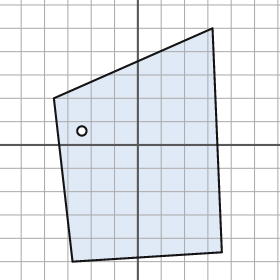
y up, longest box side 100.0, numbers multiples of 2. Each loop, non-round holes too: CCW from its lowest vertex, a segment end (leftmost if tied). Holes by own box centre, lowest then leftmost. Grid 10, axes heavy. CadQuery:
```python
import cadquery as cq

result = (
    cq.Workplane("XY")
    .moveTo(-28.0, -50.0)
    .lineTo(36.0, -46.0)
    .lineTo(32.0, 50.0)
    .lineTo(-36.0, 20.0)
    .close()
    .moveTo(-24.0, 6.0)
    .circle(2.0)
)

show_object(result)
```